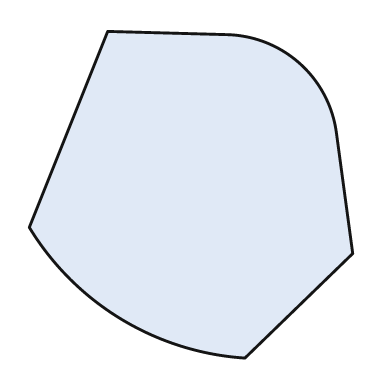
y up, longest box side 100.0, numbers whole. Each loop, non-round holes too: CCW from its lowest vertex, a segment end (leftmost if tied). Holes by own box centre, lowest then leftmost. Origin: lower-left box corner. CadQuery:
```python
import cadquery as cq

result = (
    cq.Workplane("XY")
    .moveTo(66.0, 0.0)
    .lineTo(99.0, 32.0)
    .lineTo(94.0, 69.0)
    .threePointArc((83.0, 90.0), (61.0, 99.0))
    .lineTo(24.0, 100.0)
    .lineTo(0.0, 40.0)
    .threePointArc((28.0, 12.0), (66.0, 0.0))
    .close()
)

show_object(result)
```